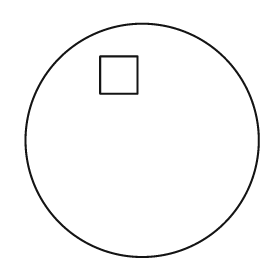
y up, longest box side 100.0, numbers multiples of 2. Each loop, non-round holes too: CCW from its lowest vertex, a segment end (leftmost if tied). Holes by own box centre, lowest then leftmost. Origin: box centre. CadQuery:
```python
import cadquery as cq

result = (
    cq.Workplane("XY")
    .moveTo(0.0, 0.0)
    .circle(50.0)
    .moveTo(-18.0, 20.0)
    .lineTo(-2.0, 20.0)
    .lineTo(-2.0, 36.0)
    .lineTo(-18.0, 36.0)
    .close()
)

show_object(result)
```